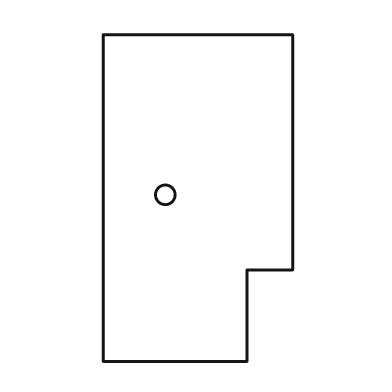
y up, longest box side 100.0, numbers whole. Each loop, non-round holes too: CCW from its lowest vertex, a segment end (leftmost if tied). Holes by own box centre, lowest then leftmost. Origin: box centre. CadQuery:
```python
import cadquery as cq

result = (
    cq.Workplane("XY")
    .moveTo(-29.0, -50.0)
    .lineTo(15.0, -50.0)
    .lineTo(15.0, -22.0)
    .lineTo(29.0, -22.0)
    .lineTo(29.0, 50.0)
    .lineTo(-29.0, 50.0)
    .close()
    .moveTo(-10.0, 1.0)
    .circle(3.0)
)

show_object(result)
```